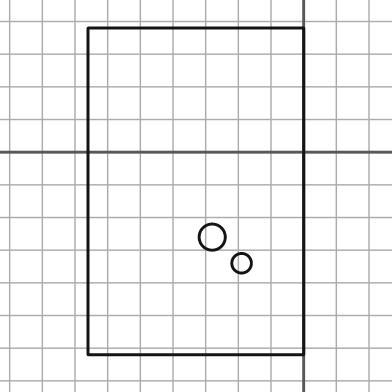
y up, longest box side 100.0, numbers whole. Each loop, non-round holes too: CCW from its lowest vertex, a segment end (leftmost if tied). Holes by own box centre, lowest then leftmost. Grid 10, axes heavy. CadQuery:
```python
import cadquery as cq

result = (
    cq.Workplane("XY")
    .moveTo(-66.0, -62.0)
    .lineTo(0.0, -62.0)
    .lineTo(0.0, 38.0)
    .lineTo(-66.0, 38.0)
    .close()
    .moveTo(-19.0, -34.0)
    .circle(3.0)
    .moveTo(-28.0, -26.0)
    .circle(4.0)
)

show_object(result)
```